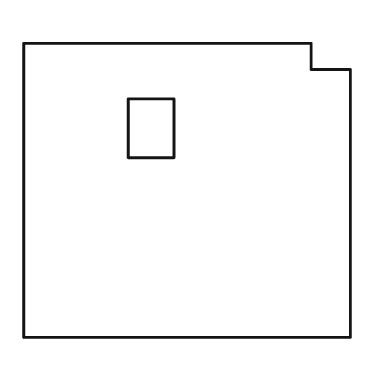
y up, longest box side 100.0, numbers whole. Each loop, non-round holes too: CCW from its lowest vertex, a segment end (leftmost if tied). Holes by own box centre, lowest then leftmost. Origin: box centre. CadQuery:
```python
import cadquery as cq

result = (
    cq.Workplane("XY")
    .moveTo(-50.0, -45.0)
    .lineTo(50.0, -45.0)
    .lineTo(50.0, 37.0)
    .lineTo(38.0, 37.0)
    .lineTo(38.0, 45.0)
    .lineTo(-50.0, 45.0)
    .close()
    .moveTo(-18.0, 10.0)
    .lineTo(-4.0, 10.0)
    .lineTo(-4.0, 28.0)
    .lineTo(-18.0, 28.0)
    .close()
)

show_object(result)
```